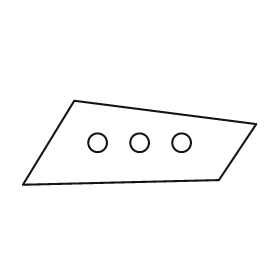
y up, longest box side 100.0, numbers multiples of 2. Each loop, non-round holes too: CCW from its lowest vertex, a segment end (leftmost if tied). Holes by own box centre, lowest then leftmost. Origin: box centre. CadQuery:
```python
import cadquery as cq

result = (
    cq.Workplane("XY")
    .moveTo(-50.0, -18.0)
    .lineTo(34.0, -16.0)
    .lineTo(50.0, 8.0)
    .lineTo(-28.0, 18.0)
    .close()
    .moveTo(-18.0, 0.0)
    .circle(4.0)
    .moveTo(0.0, 0.0)
    .circle(4.0)
    .moveTo(18.0, 0.0)
    .circle(4.0)
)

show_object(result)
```